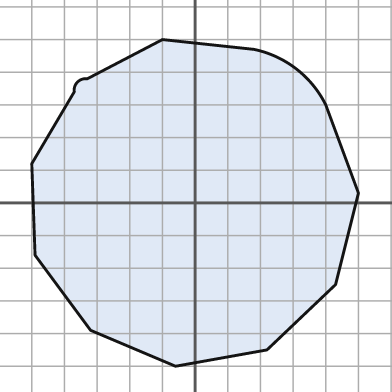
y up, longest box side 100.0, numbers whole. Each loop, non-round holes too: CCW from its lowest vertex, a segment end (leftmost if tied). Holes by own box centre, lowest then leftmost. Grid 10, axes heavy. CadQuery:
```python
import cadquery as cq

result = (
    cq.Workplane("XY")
    .moveTo(-6.0, -50.0)
    .lineTo(22.0, -45.0)
    .lineTo(43.0, -25.0)
    .lineTo(50.0, 3.0)
    .lineTo(40.0, 30.0)
    .threePointArc((31.0, 41.0), (18.0, 47.0))
    .lineTo(-10.0, 50.0)
    .lineTo(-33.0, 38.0)
    .threePointArc((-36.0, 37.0), (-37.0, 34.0))
    .lineTo(-50.0, 12.0)
    .lineTo(-49.0, -16.0)
    .lineTo(-32.0, -39.0)
    .close()
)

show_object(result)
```